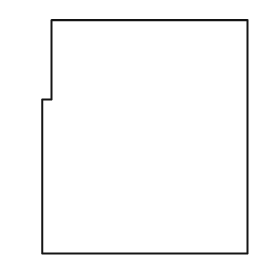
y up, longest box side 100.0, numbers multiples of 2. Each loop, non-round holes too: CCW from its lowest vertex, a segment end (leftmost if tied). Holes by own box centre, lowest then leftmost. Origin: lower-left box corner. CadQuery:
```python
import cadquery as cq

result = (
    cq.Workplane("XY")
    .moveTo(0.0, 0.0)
    .lineTo(88.0, 0.0)
    .lineTo(88.0, 100.0)
    .lineTo(4.0, 100.0)
    .lineTo(4.0, 66.0)
    .lineTo(0.0, 66.0)
    .close()
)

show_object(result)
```